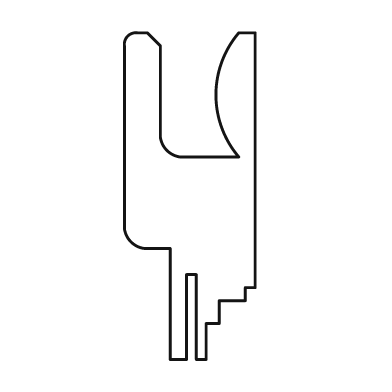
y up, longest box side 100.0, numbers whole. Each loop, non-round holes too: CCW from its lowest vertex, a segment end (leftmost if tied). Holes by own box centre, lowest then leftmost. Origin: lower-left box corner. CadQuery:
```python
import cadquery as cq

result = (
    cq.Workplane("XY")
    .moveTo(14.0, 0.0)
    .lineTo(19.0, 0.0)
    .lineTo(19.0, 26.0)
    .lineTo(22.0, 26.0)
    .lineTo(22.0, 0.0)
    .lineTo(25.0, 0.0)
    .lineTo(25.0, 11.0)
    .lineTo(29.0, 11.0)
    .lineTo(29.0, 18.0)
    .lineTo(37.0, 18.0)
    .lineTo(37.0, 22.0)
    .lineTo(40.0, 22.0)
    .lineTo(40.0, 100.0)
    .lineTo(35.0, 100.0)
    .threePointArc((28.0, 81.0), (35.0, 62.0))
    .lineTo(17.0, 62.0)
    .threePointArc((13.0, 64.0), (11.0, 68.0))
    .lineTo(11.0, 96.0)
    .lineTo(7.0, 100.0)
    .lineTo(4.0, 100.0)
    .threePointArc((1.0, 99.0), (0.0, 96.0))
    .lineTo(0.0, 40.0)
    .threePointArc((2.0, 36.0), (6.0, 34.0))
    .lineTo(14.0, 34.0)
    .close()
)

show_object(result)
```